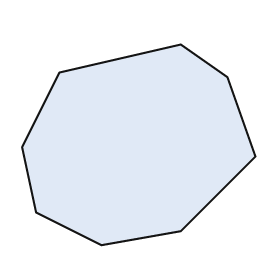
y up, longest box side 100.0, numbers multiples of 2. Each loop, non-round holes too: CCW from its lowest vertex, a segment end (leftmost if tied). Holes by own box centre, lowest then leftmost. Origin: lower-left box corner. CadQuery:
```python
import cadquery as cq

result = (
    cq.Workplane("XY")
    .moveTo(34.0, 0.0)
    .lineTo(68.0, 6.0)
    .lineTo(100.0, 38.0)
    .lineTo(88.0, 72.0)
    .lineTo(68.0, 86.0)
    .lineTo(16.0, 74.0)
    .lineTo(0.0, 42.0)
    .lineTo(6.0, 14.0)
    .close()
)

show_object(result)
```